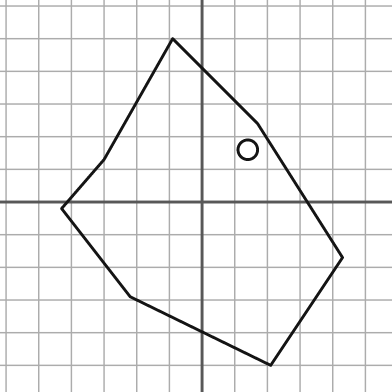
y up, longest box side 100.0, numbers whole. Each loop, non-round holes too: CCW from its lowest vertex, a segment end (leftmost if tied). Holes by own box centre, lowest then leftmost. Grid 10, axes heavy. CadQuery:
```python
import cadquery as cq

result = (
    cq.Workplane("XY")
    .moveTo(21.0, -50.0)
    .lineTo(43.0, -17.0)
    .lineTo(17.0, 24.0)
    .lineTo(-9.0, 50.0)
    .lineTo(-30.0, 13.0)
    .lineTo(-43.0, -2.0)
    .lineTo(-22.0, -29.0)
    .close()
    .moveTo(14.0, 16.0)
    .circle(3.0)
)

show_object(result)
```